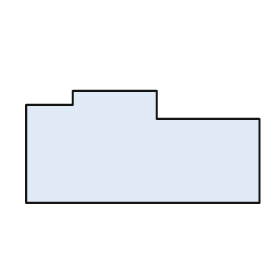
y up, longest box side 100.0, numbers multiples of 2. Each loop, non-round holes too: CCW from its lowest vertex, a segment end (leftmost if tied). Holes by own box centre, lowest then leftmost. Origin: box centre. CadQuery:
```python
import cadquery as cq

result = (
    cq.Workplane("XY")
    .moveTo(-50.0, -24.0)
    .lineTo(50.0, -24.0)
    .lineTo(50.0, 12.0)
    .lineTo(6.0, 12.0)
    .lineTo(6.0, 24.0)
    .lineTo(-30.0, 24.0)
    .lineTo(-30.0, 18.0)
    .lineTo(-50.0, 18.0)
    .close()
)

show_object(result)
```